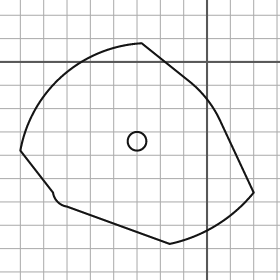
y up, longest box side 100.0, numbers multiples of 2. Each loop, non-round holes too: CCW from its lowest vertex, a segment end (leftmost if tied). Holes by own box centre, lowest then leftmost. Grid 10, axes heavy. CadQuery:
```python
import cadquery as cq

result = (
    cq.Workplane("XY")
    .moveTo(-16.0, -78.0)
    .threePointArc((4.0, -70.0), (20.0, -56.0))
    .lineTo(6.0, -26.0)
    .threePointArc((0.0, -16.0), (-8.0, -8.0))
    .lineTo(-28.0, 8.0)
    .threePointArc((-62.0, -6.0), (-80.0, -38.0))
    .lineTo(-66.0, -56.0)
    .threePointArc((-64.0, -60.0), (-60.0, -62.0))
    .close()
    .moveTo(-30.0, -34.0)
    .circle(4.0)
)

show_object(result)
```